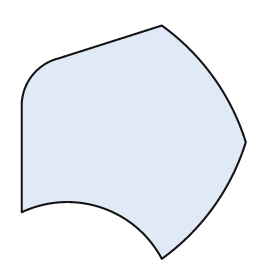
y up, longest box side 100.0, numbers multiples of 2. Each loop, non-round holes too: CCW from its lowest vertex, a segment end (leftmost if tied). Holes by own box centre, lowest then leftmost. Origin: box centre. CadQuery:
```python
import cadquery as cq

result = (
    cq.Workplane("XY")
    .moveTo(12.0, -50.0)
    .threePointArc((34.0, -28.0), (48.0, 0.0))
    .threePointArc((34.0, 28.0), (12.0, 50.0))
    .lineTo(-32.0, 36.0)
    .threePointArc((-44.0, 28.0), (-48.0, 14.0))
    .lineTo(-48.0, -30.0)
    .threePointArc((-14.0, -28.0), (12.0, -50.0))
    .close()
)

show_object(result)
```